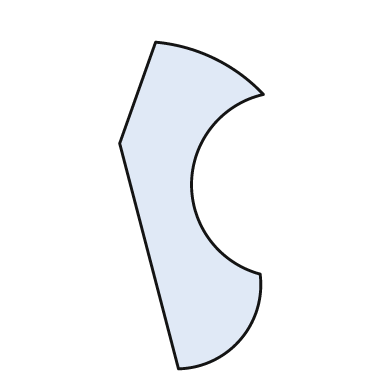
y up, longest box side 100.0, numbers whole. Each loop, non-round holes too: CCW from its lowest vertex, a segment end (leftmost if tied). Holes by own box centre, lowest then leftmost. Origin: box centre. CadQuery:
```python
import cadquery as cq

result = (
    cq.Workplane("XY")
    .moveTo(-4.0, -50.0)
    .threePointArc((15.0, -41.0), (21.0, -21.0))
    .threePointArc((0.0, 7.0), (22.0, 34.0))
    .threePointArc((7.0, 45.0), (-11.0, 50.0))
    .lineTo(-22.0, 19.0)
    .close()
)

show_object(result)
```